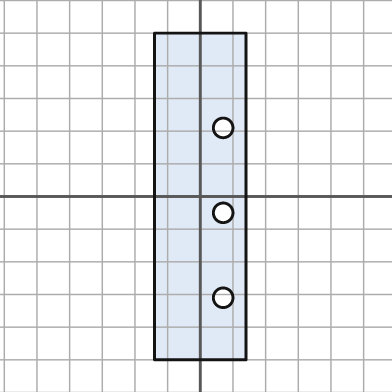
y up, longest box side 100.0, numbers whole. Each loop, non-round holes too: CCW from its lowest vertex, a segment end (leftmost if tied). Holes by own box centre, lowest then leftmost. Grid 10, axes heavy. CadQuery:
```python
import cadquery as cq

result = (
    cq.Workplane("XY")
    .moveTo(-14.0, -50.0)
    .lineTo(14.0, -50.0)
    .lineTo(14.0, 50.0)
    .lineTo(-14.0, 50.0)
    .close()
    .moveTo(7.0, -31.0)
    .circle(3.0)
    .moveTo(7.0, -5.0)
    .circle(3.0)
    .moveTo(7.0, 21.0)
    .circle(3.0)
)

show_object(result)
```